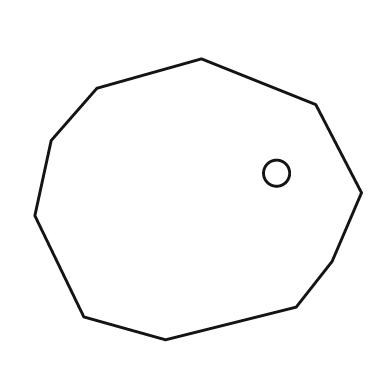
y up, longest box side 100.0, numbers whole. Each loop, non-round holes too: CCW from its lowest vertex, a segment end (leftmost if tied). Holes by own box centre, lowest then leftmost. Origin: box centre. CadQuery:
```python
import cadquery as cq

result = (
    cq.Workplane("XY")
    .moveTo(-10.0, -43.0)
    .lineTo(30.0, -33.0)
    .lineTo(41.0, -19.0)
    .lineTo(50.0, 2.0)
    .lineTo(36.0, 29.0)
    .lineTo(1.0, 43.0)
    .lineTo(-31.0, 34.0)
    .lineTo(-45.0, 18.0)
    .lineTo(-50.0, -5.0)
    .lineTo(-35.0, -36.0)
    .close()
    .moveTo(24.0, 8.0)
    .circle(4.0)
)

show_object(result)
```